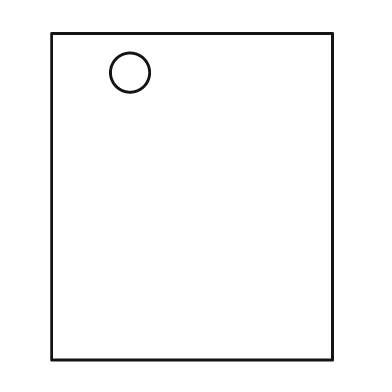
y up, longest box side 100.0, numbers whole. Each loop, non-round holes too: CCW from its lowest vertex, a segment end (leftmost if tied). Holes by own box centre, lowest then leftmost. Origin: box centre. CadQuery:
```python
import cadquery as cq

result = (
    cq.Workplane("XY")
    .moveTo(-43.0, -50.0)
    .lineTo(43.0, -50.0)
    .lineTo(43.0, 50.0)
    .lineTo(-43.0, 50.0)
    .close()
    .moveTo(-19.0, 38.0)
    .circle(6.0)
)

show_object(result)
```